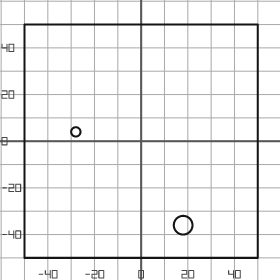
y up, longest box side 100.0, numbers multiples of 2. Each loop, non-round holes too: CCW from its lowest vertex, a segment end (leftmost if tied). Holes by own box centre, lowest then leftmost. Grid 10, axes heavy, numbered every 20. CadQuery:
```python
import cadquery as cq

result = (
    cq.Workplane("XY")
    .moveTo(-50.0, -50.0)
    .lineTo(50.0, -50.0)
    .lineTo(50.0, 50.0)
    .lineTo(-50.0, 50.0)
    .close()
    .moveTo(18.0, -36.0)
    .circle(4.0)
    .moveTo(-28.0, 4.0)
    .circle(2.0)
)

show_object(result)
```